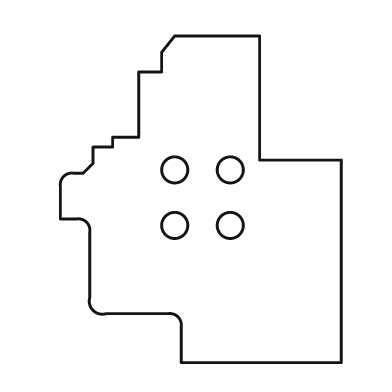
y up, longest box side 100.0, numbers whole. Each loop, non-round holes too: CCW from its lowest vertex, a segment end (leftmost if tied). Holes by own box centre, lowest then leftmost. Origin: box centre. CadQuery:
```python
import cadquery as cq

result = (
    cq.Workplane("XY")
    .moveTo(-6.0, -50.0)
    .lineTo(43.0, -50.0)
    .lineTo(43.0, 12.0)
    .lineTo(18.0, 12.0)
    .lineTo(18.0, 50.0)
    .lineTo(-8.0, 50.0)
    .lineTo(-12.0, 45.0)
    .lineTo(-12.0, 39.0)
    .lineTo(-19.0, 39.0)
    .lineTo(-19.0, 19.0)
    .lineTo(-27.0, 19.0)
    .lineTo(-27.0, 16.0)
    .lineTo(-33.0, 16.0)
    .lineTo(-33.0, 11.0)
    .lineTo(-36.0, 8.0)
    .lineTo(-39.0, 8.0)
    .threePointArc((-42.0, 7.0), (-43.0, 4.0))
    .lineTo(-43.0, -6.0)
    .lineTo(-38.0, -6.0)
    .threePointArc((-35.0, -7.0), (-34.0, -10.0))
    .lineTo(-34.0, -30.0)
    .threePointArc((-33.0, -34.0), (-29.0, -35.0))
    .lineTo(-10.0, -35.0)
    .threePointArc((-7.0, -36.0), (-6.0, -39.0))
    .close()
    .moveTo(-8.0, -8.0)
    .circle(4.0)
    .moveTo(9.0, -8.0)
    .circle(4.0)
    .moveTo(-8.0, 9.0)
    .circle(4.0)
    .moveTo(9.0, 9.0)
    .circle(4.0)
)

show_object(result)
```